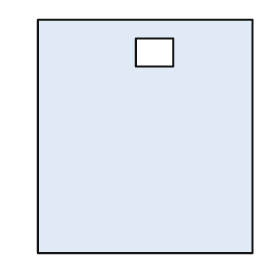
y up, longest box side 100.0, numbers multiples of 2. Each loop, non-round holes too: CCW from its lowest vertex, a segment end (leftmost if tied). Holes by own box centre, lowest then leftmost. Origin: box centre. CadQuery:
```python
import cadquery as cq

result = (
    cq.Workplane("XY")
    .moveTo(-46.0, -50.0)
    .lineTo(46.0, -50.0)
    .lineTo(46.0, 50.0)
    .lineTo(-46.0, 50.0)
    .close()
    .moveTo(-4.0, 30.0)
    .lineTo(12.0, 30.0)
    .lineTo(12.0, 42.0)
    .lineTo(-4.0, 42.0)
    .close()
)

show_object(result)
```